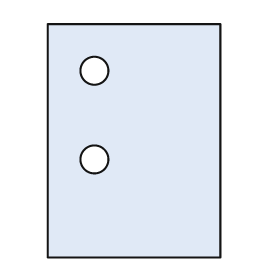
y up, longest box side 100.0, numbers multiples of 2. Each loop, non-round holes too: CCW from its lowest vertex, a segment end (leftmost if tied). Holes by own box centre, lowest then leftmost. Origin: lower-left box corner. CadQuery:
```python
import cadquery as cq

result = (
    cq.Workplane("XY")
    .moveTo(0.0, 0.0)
    .lineTo(74.0, 0.0)
    .lineTo(74.0, 100.0)
    .lineTo(0.0, 100.0)
    .close()
    .moveTo(20.0, 42.0)
    .circle(6.0)
    .moveTo(20.0, 80.0)
    .circle(6.0)
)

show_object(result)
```